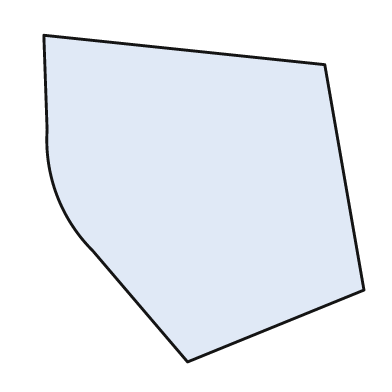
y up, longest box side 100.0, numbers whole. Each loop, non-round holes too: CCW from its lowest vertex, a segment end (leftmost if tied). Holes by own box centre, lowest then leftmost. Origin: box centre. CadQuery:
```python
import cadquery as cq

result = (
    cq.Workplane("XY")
    .moveTo(-5.0, -50.0)
    .lineTo(49.0, -28.0)
    .lineTo(37.0, 41.0)
    .lineTo(-49.0, 50.0)
    .lineTo(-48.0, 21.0)
    .threePointArc((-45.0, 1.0), (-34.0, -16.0))
    .close()
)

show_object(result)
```